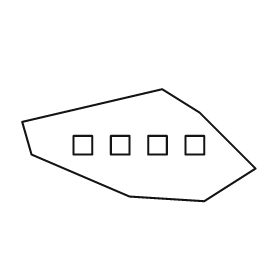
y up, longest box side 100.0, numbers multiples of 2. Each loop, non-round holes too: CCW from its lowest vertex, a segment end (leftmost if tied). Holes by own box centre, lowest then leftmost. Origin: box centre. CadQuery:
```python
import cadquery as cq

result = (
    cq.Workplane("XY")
    .moveTo(28.0, -24.0)
    .lineTo(50.0, -10.0)
    .lineTo(26.0, 14.0)
    .lineTo(10.0, 24.0)
    .lineTo(-50.0, 10.0)
    .lineTo(-46.0, -4.0)
    .lineTo(-4.0, -22.0)
    .close()
    .moveTo(-28.0, -4.0)
    .lineTo(-20.0, -4.0)
    .lineTo(-20.0, 4.0)
    .lineTo(-28.0, 4.0)
    .close()
    .moveTo(-12.0, -4.0)
    .lineTo(-4.0, -4.0)
    .lineTo(-4.0, 4.0)
    .lineTo(-12.0, 4.0)
    .close()
    .moveTo(4.0, -4.0)
    .lineTo(12.0, -4.0)
    .lineTo(12.0, 4.0)
    .lineTo(4.0, 4.0)
    .close()
    .moveTo(20.0, -4.0)
    .lineTo(28.0, -4.0)
    .lineTo(28.0, 4.0)
    .lineTo(20.0, 4.0)
    .close()
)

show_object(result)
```